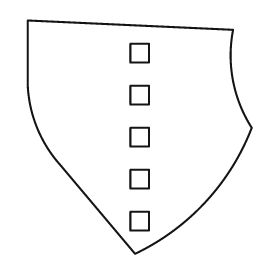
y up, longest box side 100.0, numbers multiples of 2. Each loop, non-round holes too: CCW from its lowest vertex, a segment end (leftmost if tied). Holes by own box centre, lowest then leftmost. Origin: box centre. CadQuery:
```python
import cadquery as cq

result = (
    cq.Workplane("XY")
    .moveTo(-2.0, -50.0)
    .threePointArc((28.0, -28.0), (48.0, 4.0))
    .threePointArc((40.0, 24.0), (40.0, 46.0))
    .lineTo(-48.0, 50.0)
    .lineTo(-48.0, 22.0)
    .threePointArc((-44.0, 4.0), (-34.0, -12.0))
    .close()
    .moveTo(-4.0, -40.0)
    .lineTo(4.0, -40.0)
    .lineTo(4.0, -32.0)
    .lineTo(-4.0, -32.0)
    .close()
    .moveTo(-4.0, -22.0)
    .lineTo(4.0, -22.0)
    .lineTo(4.0, -14.0)
    .lineTo(-4.0, -14.0)
    .close()
    .moveTo(-4.0, -4.0)
    .lineTo(4.0, -4.0)
    .lineTo(4.0, 4.0)
    .lineTo(-4.0, 4.0)
    .close()
    .moveTo(-4.0, 14.0)
    .lineTo(4.0, 14.0)
    .lineTo(4.0, 22.0)
    .lineTo(-4.0, 22.0)
    .close()
    .moveTo(-4.0, 32.0)
    .lineTo(4.0, 32.0)
    .lineTo(4.0, 40.0)
    .lineTo(-4.0, 40.0)
    .close()
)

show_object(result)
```